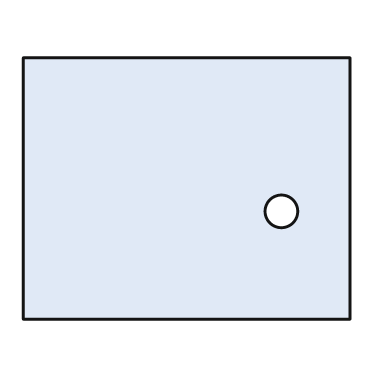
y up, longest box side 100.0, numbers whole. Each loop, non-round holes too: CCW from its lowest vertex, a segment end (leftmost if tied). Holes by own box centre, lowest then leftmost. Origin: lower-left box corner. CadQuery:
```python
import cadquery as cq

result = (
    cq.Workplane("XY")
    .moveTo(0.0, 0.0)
    .lineTo(100.0, 0.0)
    .lineTo(100.0, 80.0)
    .lineTo(0.0, 80.0)
    .close()
    .moveTo(79.0, 33.0)
    .circle(5.0)
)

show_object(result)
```